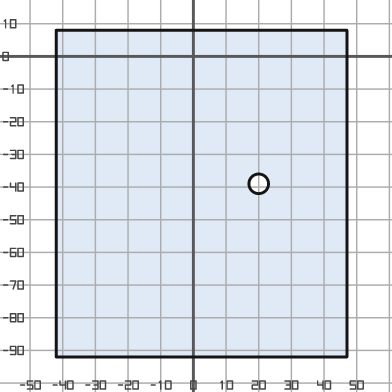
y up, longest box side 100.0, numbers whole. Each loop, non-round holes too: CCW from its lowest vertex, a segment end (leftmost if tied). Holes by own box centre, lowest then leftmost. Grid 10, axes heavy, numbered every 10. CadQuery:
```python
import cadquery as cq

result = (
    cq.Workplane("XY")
    .moveTo(-42.0, -92.0)
    .lineTo(47.0, -92.0)
    .lineTo(47.0, 8.0)
    .lineTo(-42.0, 8.0)
    .close()
    .moveTo(20.0, -39.0)
    .circle(3.0)
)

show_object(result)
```